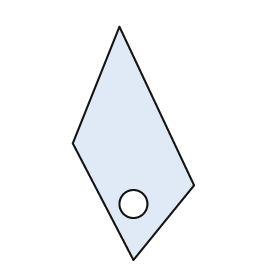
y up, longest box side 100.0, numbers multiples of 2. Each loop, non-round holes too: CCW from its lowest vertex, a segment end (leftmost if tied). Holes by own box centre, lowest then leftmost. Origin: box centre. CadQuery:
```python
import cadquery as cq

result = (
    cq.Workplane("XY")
    .moveTo(0.0, -50.0)
    .lineTo(26.0, -18.0)
    .lineTo(-6.0, 50.0)
    .lineTo(-26.0, 0.0)
    .close()
    .moveTo(0.0, -26.0)
    .circle(6.0)
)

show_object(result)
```